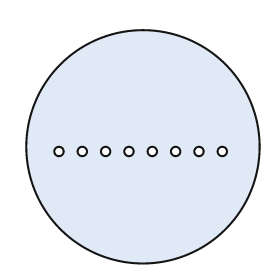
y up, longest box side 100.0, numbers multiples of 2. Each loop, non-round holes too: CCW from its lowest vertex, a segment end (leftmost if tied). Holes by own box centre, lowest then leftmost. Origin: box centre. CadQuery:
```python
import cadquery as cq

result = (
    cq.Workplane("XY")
    .moveTo(0.0, 0.0)
    .circle(50.0)
    .moveTo(-36.0, -2.0)
    .circle(2.0)
    .moveTo(-26.0, -2.0)
    .circle(2.0)
    .moveTo(-16.0, -2.0)
    .circle(2.0)
    .moveTo(-6.0, -2.0)
    .circle(2.0)
    .moveTo(4.0, -2.0)
    .circle(2.0)
    .moveTo(14.0, -2.0)
    .circle(2.0)
    .moveTo(24.0, -2.0)
    .circle(2.0)
    .moveTo(34.0, -2.0)
    .circle(2.0)
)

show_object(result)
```